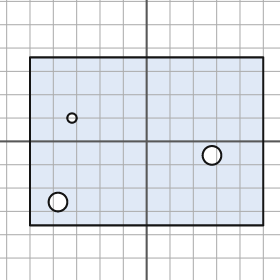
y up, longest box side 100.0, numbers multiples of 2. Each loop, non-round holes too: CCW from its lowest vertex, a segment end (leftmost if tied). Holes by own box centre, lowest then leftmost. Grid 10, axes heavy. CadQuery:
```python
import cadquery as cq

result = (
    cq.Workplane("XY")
    .moveTo(-50.0, -36.0)
    .lineTo(50.0, -36.0)
    .lineTo(50.0, 36.0)
    .lineTo(-50.0, 36.0)
    .close()
    .moveTo(-38.0, -26.0)
    .circle(4.0)
    .moveTo(28.0, -6.0)
    .circle(4.0)
    .moveTo(-32.0, 10.0)
    .circle(2.0)
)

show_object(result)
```